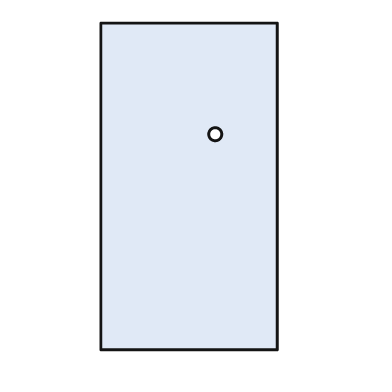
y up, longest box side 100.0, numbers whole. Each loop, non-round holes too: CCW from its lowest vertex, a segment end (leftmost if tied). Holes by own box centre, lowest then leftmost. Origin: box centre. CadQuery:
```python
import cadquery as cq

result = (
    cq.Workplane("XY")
    .moveTo(-27.0, -50.0)
    .lineTo(27.0, -50.0)
    .lineTo(27.0, 50.0)
    .lineTo(-27.0, 50.0)
    .close()
    .moveTo(8.0, 16.0)
    .circle(2.0)
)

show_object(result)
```